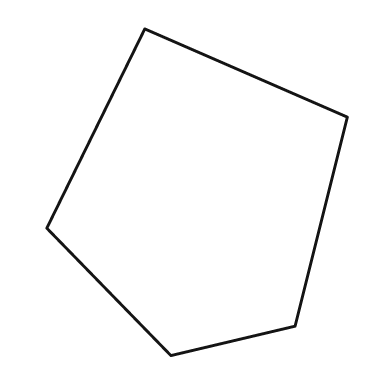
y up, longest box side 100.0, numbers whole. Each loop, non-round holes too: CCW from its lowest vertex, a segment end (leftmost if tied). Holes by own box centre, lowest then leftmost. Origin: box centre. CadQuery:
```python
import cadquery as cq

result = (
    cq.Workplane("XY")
    .moveTo(-8.0, -50.0)
    .lineTo(30.0, -41.0)
    .lineTo(46.0, 23.0)
    .lineTo(-16.0, 50.0)
    .lineTo(-46.0, -11.0)
    .close()
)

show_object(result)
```